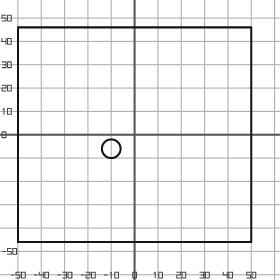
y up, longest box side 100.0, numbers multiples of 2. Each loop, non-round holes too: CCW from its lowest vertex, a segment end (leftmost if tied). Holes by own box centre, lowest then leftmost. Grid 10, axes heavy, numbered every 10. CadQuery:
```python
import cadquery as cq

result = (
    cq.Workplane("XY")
    .moveTo(-50.0, -46.0)
    .lineTo(50.0, -46.0)
    .lineTo(50.0, 46.0)
    .lineTo(-50.0, 46.0)
    .close()
    .moveTo(-10.0, -6.0)
    .circle(4.0)
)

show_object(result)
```